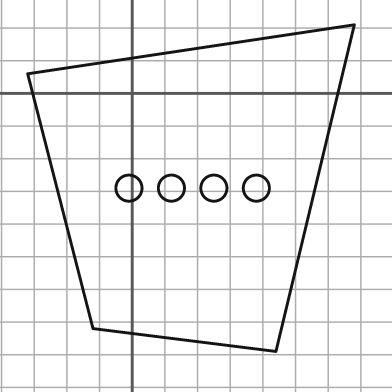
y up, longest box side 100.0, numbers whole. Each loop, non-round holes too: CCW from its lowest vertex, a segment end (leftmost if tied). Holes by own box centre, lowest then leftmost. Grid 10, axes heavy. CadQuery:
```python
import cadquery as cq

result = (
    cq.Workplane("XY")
    .moveTo(44.0, -79.0)
    .lineTo(68.0, 21.0)
    .lineTo(-32.0, 6.0)
    .lineTo(-12.0, -72.0)
    .close()
    .moveTo(-1.0, -29.0)
    .circle(4.0)
    .moveTo(12.0, -29.0)
    .circle(4.0)
    .moveTo(25.0, -29.0)
    .circle(4.0)
    .moveTo(38.0, -29.0)
    .circle(4.0)
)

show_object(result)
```